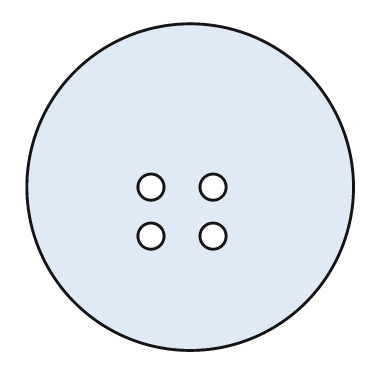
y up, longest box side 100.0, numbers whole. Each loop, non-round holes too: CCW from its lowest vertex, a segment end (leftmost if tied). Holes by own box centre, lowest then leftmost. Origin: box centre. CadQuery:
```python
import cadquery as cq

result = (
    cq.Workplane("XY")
    .moveTo(0.0, 0.0)
    .circle(50.0)
    .moveTo(-12.0, -15.0)
    .circle(4.0)
    .moveTo(7.0, -15.0)
    .circle(4.0)
    .moveTo(-12.0, 0.0)
    .circle(4.0)
    .moveTo(7.0, 0.0)
    .circle(4.0)
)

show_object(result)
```